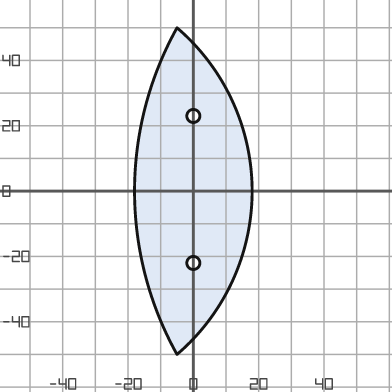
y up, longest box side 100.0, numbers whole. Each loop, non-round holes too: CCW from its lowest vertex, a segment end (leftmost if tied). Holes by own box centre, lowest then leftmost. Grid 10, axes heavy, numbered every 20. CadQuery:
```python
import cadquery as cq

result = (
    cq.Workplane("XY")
    .moveTo(-5.0, -50.0)
    .threePointArc((18.0, 0.0), (-5.0, 50.0))
    .threePointArc((-18.0, 0.0), (-5.0, -50.0))
    .close()
    .moveTo(0.0, -22.0)
    .circle(2.0)
    .moveTo(0.0, 23.0)
    .circle(2.0)
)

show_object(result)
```